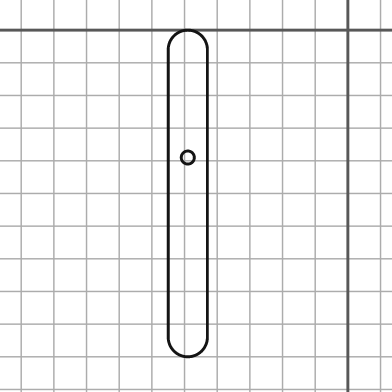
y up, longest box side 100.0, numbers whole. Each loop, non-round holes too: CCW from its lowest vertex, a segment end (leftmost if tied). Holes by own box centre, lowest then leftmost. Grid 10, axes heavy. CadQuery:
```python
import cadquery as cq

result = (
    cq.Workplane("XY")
    .moveTo(-55.0, -94.0)
    .threePointArc((-49.0, -100.0), (-43.0, -94.0))
    .lineTo(-43.0, -6.0)
    .threePointArc((-49.0, 0.0), (-55.0, -6.0))
    .close()
    .moveTo(-49.0, -39.0)
    .circle(2.0)
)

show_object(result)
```